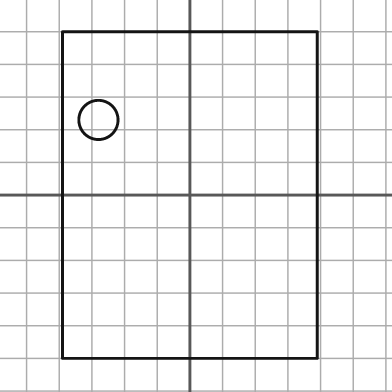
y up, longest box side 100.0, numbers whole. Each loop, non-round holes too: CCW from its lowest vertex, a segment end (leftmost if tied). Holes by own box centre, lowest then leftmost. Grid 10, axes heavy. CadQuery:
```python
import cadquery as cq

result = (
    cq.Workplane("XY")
    .moveTo(-39.0, -50.0)
    .lineTo(39.0, -50.0)
    .lineTo(39.0, 50.0)
    .lineTo(-39.0, 50.0)
    .close()
    .moveTo(-28.0, 23.0)
    .circle(6.0)
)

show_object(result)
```